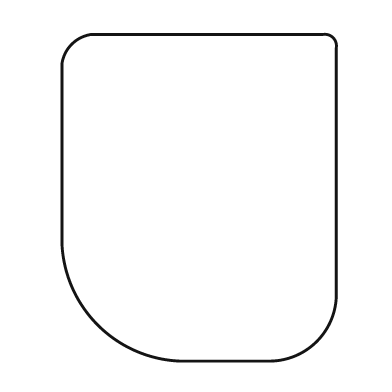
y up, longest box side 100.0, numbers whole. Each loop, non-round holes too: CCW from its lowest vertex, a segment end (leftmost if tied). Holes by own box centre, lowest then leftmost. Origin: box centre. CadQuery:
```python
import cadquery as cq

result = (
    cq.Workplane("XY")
    .moveTo(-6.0, -50.0)
    .lineTo(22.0, -50.0)
    .threePointArc((36.0, -44.0), (42.0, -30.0))
    .lineTo(42.0, 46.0)
    .threePointArc((41.0, 49.0), (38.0, 50.0))
    .lineTo(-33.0, 50.0)
    .threePointArc((-39.0, 47.0), (-42.0, 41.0))
    .lineTo(-42.0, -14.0)
    .threePointArc((-31.0, -39.0), (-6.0, -50.0))
    .close()
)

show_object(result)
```